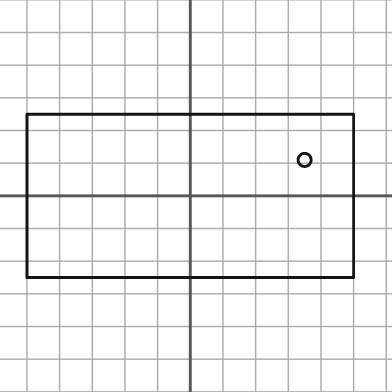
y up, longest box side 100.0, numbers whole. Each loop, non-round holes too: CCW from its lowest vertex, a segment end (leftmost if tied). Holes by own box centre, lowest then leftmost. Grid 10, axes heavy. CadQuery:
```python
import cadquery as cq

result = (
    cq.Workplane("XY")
    .moveTo(-50.0, -25.0)
    .lineTo(50.0, -25.0)
    .lineTo(50.0, 25.0)
    .lineTo(-50.0, 25.0)
    .close()
    .moveTo(35.0, 11.0)
    .circle(2.0)
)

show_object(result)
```